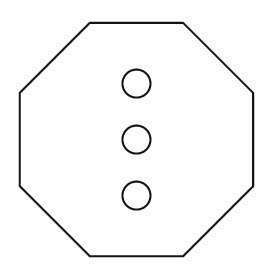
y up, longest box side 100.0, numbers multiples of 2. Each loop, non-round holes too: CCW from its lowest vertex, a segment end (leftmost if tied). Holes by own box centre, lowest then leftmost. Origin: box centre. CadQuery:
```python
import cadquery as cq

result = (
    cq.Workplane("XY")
    .moveTo(-20.0, -50.0)
    .lineTo(20.0, -50.0)
    .lineTo(50.0, -20.0)
    .lineTo(50.0, 20.0)
    .lineTo(20.0, 50.0)
    .lineTo(-20.0, 50.0)
    .lineTo(-50.0, 20.0)
    .lineTo(-50.0, -20.0)
    .close()
    .moveTo(0.0, -24.0)
    .circle(6.0)
    .moveTo(0.0, 0.0)
    .circle(6.0)
    .moveTo(0.0, 24.0)
    .circle(6.0)
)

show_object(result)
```